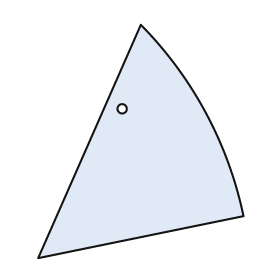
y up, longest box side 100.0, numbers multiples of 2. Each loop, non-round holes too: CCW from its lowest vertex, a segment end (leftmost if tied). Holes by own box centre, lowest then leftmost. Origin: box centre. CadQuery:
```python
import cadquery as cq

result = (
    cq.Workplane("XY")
    .moveTo(-44.0, -50.0)
    .lineTo(44.0, -32.0)
    .threePointArc((28.0, 12.0), (0.0, 50.0))
    .close()
    .moveTo(-8.0, 14.0)
    .circle(2.0)
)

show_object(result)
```